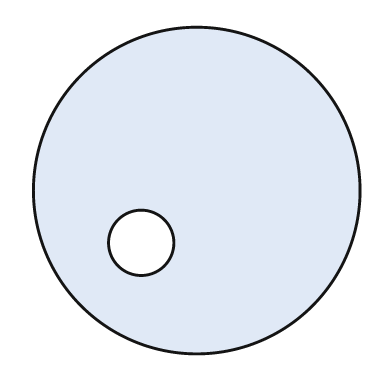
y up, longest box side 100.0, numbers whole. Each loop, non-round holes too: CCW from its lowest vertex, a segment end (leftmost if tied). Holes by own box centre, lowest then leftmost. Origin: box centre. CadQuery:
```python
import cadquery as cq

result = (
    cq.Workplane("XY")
    .moveTo(0.0, 0.0)
    .circle(50.0)
    .moveTo(-17.0, -16.0)
    .circle(10.0)
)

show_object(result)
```